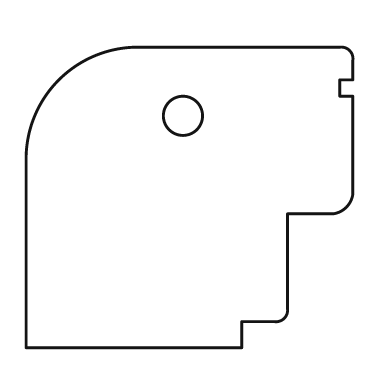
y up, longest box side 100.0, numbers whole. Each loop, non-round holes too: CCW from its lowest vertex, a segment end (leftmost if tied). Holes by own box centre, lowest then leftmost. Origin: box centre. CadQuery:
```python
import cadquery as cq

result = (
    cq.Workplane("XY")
    .moveTo(-50.0, -46.0)
    .lineTo(16.0, -46.0)
    .lineTo(16.0, -38.0)
    .lineTo(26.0, -38.0)
    .threePointArc((29.0, -37.0), (30.0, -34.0))
    .lineTo(30.0, -5.0)
    .lineTo(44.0, -5.0)
    .threePointArc((48.0, -3.0), (50.0, 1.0))
    .lineTo(50.0, 31.0)
    .lineTo(46.0, 31.0)
    .lineTo(46.0, 36.0)
    .lineTo(50.0, 36.0)
    .lineTo(50.0, 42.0)
    .threePointArc((49.0, 45.0), (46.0, 46.0))
    .lineTo(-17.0, 46.0)
    .threePointArc((-40.0, 36.0), (-50.0, 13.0))
    .close()
    .moveTo(-2.0, 25.0)
    .circle(6.0)
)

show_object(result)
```